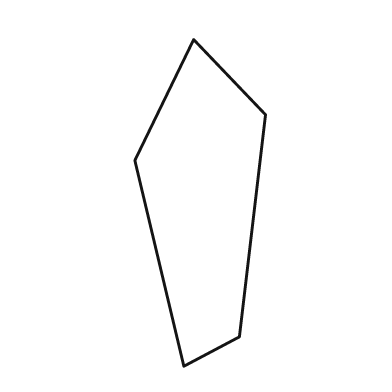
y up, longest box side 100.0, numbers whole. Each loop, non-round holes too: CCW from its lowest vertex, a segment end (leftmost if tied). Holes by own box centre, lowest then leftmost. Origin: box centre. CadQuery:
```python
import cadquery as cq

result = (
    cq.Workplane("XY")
    .moveTo(-5.0, -50.0)
    .lineTo(12.0, -41.0)
    .lineTo(20.0, 27.0)
    .lineTo(-2.0, 50.0)
    .lineTo(-20.0, 13.0)
    .close()
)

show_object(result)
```